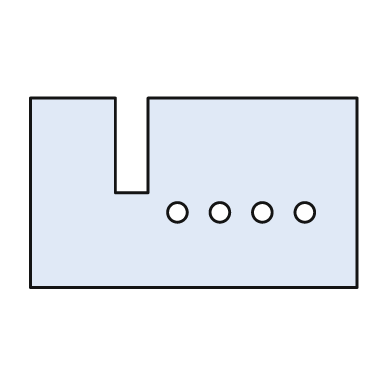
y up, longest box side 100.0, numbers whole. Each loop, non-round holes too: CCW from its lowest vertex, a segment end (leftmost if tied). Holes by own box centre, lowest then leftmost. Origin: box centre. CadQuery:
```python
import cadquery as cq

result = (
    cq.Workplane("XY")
    .moveTo(-50.0, -29.0)
    .lineTo(50.0, -29.0)
    .lineTo(50.0, 29.0)
    .lineTo(-14.0, 29.0)
    .lineTo(-14.0, 0.0)
    .lineTo(-24.0, 0.0)
    .lineTo(-24.0, 29.0)
    .lineTo(-50.0, 29.0)
    .close()
    .moveTo(-5.0, -6.0)
    .circle(3.0)
    .moveTo(8.0, -6.0)
    .circle(3.0)
    .moveTo(21.0, -6.0)
    .circle(3.0)
    .moveTo(34.0, -6.0)
    .circle(3.0)
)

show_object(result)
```